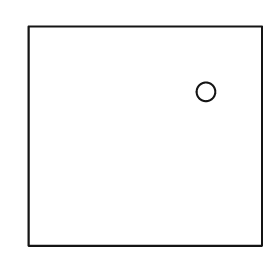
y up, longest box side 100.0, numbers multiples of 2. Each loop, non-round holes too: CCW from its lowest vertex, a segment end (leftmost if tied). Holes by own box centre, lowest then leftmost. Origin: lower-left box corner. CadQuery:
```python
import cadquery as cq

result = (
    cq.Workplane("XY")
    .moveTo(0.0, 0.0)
    .lineTo(100.0, 0.0)
    .lineTo(100.0, 94.0)
    .lineTo(0.0, 94.0)
    .close()
    .moveTo(76.0, 66.0)
    .circle(4.0)
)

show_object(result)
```